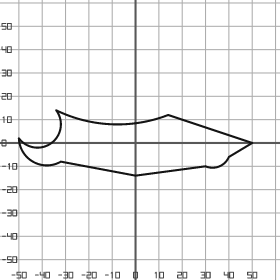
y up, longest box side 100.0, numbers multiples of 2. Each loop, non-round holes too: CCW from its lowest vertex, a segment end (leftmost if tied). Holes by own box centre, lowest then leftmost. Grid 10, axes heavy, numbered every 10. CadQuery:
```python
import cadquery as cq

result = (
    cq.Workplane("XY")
    .moveTo(0.0, -14.0)
    .lineTo(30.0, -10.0)
    .threePointArc((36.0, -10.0), (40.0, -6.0))
    .lineTo(50.0, 0.0)
    .lineTo(14.0, 12.0)
    .threePointArc((-10.0, 8.0), (-34.0, 14.0))
    .threePointArc((-36.0, 0.0), (-50.0, 2.0))
    .threePointArc((-44.0, -8.0), (-32.0, -8.0))
    .close()
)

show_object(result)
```